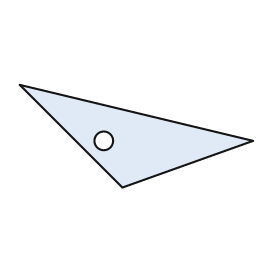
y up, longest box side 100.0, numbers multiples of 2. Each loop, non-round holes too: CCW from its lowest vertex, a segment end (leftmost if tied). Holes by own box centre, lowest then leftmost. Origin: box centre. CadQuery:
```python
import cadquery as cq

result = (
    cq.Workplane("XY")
    .moveTo(-6.0, -22.0)
    .lineTo(50.0, -2.0)
    .lineTo(-50.0, 22.0)
    .close()
    .moveTo(-14.0, -2.0)
    .circle(4.0)
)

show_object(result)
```